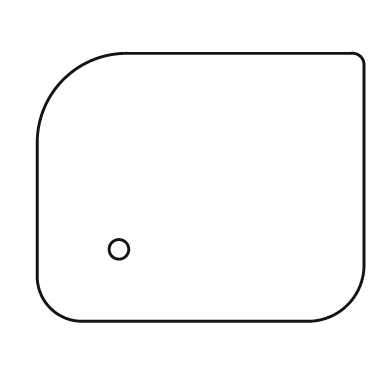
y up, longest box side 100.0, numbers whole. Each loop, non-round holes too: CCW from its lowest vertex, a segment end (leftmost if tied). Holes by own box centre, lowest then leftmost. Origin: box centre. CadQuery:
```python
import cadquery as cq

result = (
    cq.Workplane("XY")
    .moveTo(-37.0, -41.0)
    .lineTo(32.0, -41.0)
    .threePointArc((45.0, -36.0), (50.0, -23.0))
    .lineTo(50.0, 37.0)
    .threePointArc((49.0, 40.0), (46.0, 41.0))
    .lineTo(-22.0, 41.0)
    .threePointArc((-42.0, 33.0), (-50.0, 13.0))
    .lineTo(-50.0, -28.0)
    .threePointArc((-46.0, -37.0), (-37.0, -41.0))
    .close()
    .moveTo(-25.0, -19.0)
    .circle(3.0)
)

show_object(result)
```